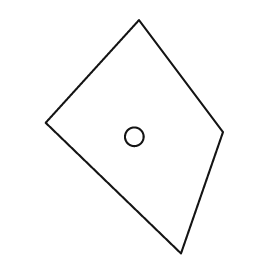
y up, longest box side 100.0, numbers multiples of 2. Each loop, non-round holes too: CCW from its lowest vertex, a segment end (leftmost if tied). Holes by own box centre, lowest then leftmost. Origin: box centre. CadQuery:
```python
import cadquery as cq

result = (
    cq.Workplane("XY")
    .moveTo(20.0, -50.0)
    .lineTo(38.0, 2.0)
    .lineTo(2.0, 50.0)
    .lineTo(-38.0, 6.0)
    .close()
    .moveTo(0.0, 0.0)
    .circle(4.0)
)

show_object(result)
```